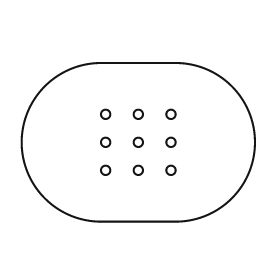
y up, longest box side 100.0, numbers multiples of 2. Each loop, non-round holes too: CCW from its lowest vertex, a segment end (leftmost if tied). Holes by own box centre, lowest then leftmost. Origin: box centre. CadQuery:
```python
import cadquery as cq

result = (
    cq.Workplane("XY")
    .moveTo(-16.0, -34.0)
    .lineTo(16.0, -34.0)
    .threePointArc((50.0, 0.0), (16.0, 34.0))
    .lineTo(-16.0, 34.0)
    .threePointArc((-50.0, 0.0), (-16.0, -34.0))
    .close()
    .moveTo(-14.0, -12.0)
    .circle(2.0)
    .moveTo(0.0, -12.0)
    .circle(2.0)
    .moveTo(14.0, -12.0)
    .circle(2.0)
    .moveTo(-14.0, 0.0)
    .circle(2.0)
    .moveTo(0.0, 0.0)
    .circle(2.0)
    .moveTo(14.0, 0.0)
    .circle(2.0)
    .moveTo(-14.0, 12.0)
    .circle(2.0)
    .moveTo(0.0, 12.0)
    .circle(2.0)
    .moveTo(14.0, 12.0)
    .circle(2.0)
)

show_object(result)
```